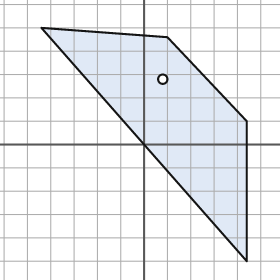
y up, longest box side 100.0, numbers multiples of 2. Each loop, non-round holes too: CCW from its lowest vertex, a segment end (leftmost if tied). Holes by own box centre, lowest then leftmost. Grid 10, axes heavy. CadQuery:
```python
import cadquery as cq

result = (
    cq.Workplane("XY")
    .moveTo(44.0, -50.0)
    .lineTo(44.0, 10.0)
    .lineTo(10.0, 46.0)
    .lineTo(-44.0, 50.0)
    .close()
    .moveTo(8.0, 28.0)
    .circle(2.0)
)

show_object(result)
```